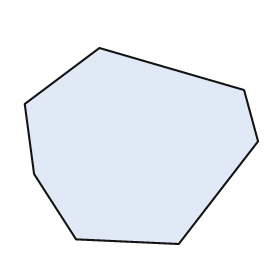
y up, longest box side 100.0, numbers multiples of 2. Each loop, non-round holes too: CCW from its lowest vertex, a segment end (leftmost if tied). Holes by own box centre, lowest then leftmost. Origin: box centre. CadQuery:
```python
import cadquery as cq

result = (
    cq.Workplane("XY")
    .moveTo(16.0, -42.0)
    .lineTo(50.0, 2.0)
    .lineTo(44.0, 24.0)
    .lineTo(-18.0, 42.0)
    .lineTo(-50.0, 18.0)
    .lineTo(-46.0, -12.0)
    .lineTo(-28.0, -40.0)
    .close()
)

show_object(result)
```